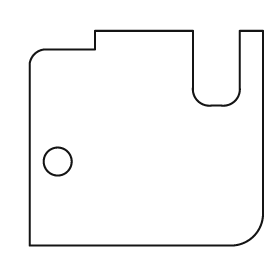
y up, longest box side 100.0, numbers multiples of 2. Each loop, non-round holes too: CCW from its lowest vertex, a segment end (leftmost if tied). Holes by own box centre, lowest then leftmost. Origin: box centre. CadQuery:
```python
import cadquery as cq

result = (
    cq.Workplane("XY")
    .moveTo(-50.0, -46.0)
    .lineTo(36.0, -46.0)
    .threePointArc((46.0, -42.0), (50.0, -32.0))
    .lineTo(50.0, 46.0)
    .lineTo(40.0, 46.0)
    .lineTo(40.0, 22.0)
    .threePointArc((38.0, 16.0), (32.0, 14.0))
    .lineTo(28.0, 14.0)
    .threePointArc((22.0, 16.0), (20.0, 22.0))
    .lineTo(20.0, 46.0)
    .lineTo(-22.0, 46.0)
    .lineTo(-22.0, 38.0)
    .lineTo(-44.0, 38.0)
    .threePointArc((-48.0, 36.0), (-50.0, 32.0))
    .close()
    .moveTo(-38.0, -10.0)
    .circle(6.0)
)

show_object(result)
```